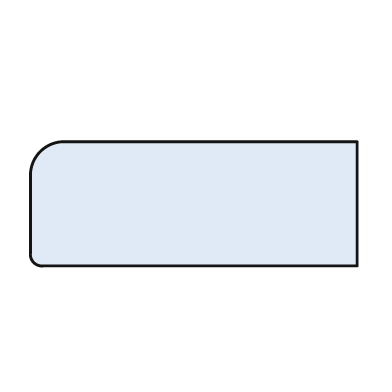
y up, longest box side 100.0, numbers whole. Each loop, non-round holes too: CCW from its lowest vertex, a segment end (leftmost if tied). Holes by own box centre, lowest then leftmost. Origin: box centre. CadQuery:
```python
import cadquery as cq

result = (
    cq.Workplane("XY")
    .moveTo(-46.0, -19.0)
    .lineTo(50.0, -19.0)
    .lineTo(50.0, 19.0)
    .lineTo(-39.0, 19.0)
    .threePointArc((-47.0, 16.0), (-50.0, 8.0))
    .lineTo(-50.0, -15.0)
    .threePointArc((-49.0, -18.0), (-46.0, -19.0))
    .close()
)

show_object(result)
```